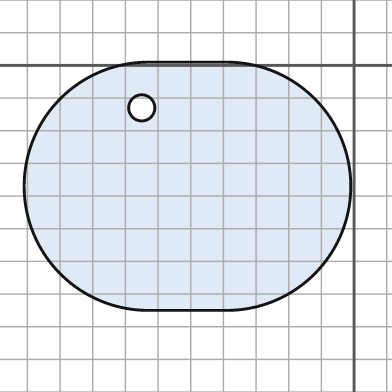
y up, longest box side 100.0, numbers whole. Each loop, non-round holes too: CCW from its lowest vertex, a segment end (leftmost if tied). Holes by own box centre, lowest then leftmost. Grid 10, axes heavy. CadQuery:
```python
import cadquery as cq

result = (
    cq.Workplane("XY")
    .moveTo(-63.0, -75.0)
    .lineTo(-39.0, -75.0)
    .threePointArc((-1.0, -37.0), (-39.0, 1.0))
    .lineTo(-63.0, 1.0)
    .threePointArc((-101.0, -37.0), (-63.0, -75.0))
    .close()
    .moveTo(-65.0, -13.0)
    .circle(4.0)
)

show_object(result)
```